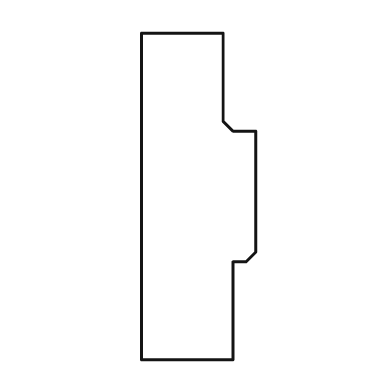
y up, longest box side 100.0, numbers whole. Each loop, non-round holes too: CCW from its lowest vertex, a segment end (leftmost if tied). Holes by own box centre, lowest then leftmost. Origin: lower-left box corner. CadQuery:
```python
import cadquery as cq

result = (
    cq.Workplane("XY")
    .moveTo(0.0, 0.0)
    .lineTo(28.0, 0.0)
    .lineTo(28.0, 30.0)
    .lineTo(32.0, 30.0)
    .lineTo(35.0, 33.0)
    .lineTo(35.0, 70.0)
    .lineTo(28.0, 70.0)
    .lineTo(25.0, 73.0)
    .lineTo(25.0, 100.0)
    .lineTo(0.0, 100.0)
    .close()
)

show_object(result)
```